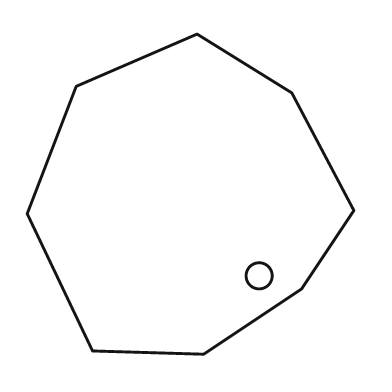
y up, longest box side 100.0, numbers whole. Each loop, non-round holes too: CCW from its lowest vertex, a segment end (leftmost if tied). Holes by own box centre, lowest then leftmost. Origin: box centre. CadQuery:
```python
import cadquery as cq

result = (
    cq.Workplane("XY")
    .moveTo(4.0, -49.0)
    .lineTo(34.0, -29.0)
    .lineTo(50.0, -5.0)
    .lineTo(31.0, 31.0)
    .lineTo(2.0, 49.0)
    .lineTo(-35.0, 33.0)
    .lineTo(-50.0, -6.0)
    .lineTo(-30.0, -48.0)
    .close()
    .moveTo(21.0, -25.0)
    .circle(4.0)
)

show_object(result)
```